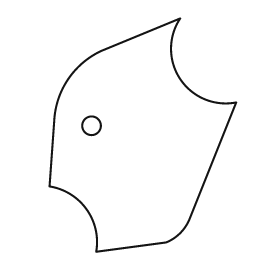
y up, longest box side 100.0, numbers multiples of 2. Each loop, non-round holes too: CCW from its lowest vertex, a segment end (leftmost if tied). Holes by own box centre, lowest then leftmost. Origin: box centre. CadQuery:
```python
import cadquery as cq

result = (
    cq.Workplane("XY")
    .moveTo(-20.0, -50.0)
    .lineTo(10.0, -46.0)
    .threePointArc((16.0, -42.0), (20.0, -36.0))
    .lineTo(40.0, 14.0)
    .threePointArc((16.0, 24.0), (16.0, 50.0))
    .lineTo(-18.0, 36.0)
    .threePointArc((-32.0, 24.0), (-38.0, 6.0))
    .lineTo(-40.0, -22.0)
    .threePointArc((-24.0, -32.0), (-20.0, -50.0))
    .close()
    .moveTo(-22.0, 4.0)
    .circle(4.0)
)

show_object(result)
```